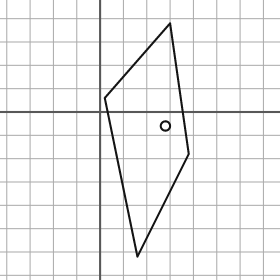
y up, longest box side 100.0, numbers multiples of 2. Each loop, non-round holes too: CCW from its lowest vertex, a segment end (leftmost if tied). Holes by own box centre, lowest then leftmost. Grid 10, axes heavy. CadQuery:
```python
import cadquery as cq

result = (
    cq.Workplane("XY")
    .moveTo(16.0, -62.0)
    .lineTo(38.0, -18.0)
    .lineTo(30.0, 38.0)
    .lineTo(2.0, 6.0)
    .close()
    .moveTo(28.0, -6.0)
    .circle(2.0)
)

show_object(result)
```